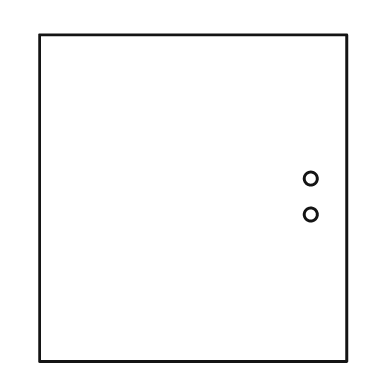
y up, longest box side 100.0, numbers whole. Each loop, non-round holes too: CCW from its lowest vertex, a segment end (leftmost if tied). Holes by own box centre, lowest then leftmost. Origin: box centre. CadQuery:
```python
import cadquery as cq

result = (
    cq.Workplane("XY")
    .moveTo(-47.0, -50.0)
    .lineTo(47.0, -50.0)
    .lineTo(47.0, 50.0)
    .lineTo(-47.0, 50.0)
    .close()
    .moveTo(36.0, -5.0)
    .circle(2.0)
    .moveTo(36.0, 6.0)
    .circle(2.0)
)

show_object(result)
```